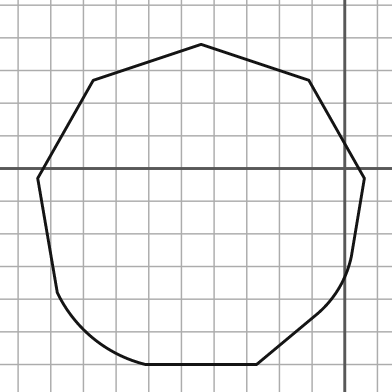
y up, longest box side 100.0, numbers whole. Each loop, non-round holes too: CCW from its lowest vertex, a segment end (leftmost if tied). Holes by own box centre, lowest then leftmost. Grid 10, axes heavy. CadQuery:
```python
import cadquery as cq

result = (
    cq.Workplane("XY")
    .moveTo(-61.0, -60.0)
    .lineTo(-27.0, -60.0)
    .lineTo(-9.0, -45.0)
    .threePointArc((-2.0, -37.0), (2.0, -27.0))
    .lineTo(6.0, -3.0)
    .lineTo(-11.0, 27.0)
    .lineTo(-44.0, 38.0)
    .lineTo(-77.0, 27.0)
    .lineTo(-94.0, -3.0)
    .lineTo(-88.0, -38.0)
    .threePointArc((-77.0, -52.0), (-61.0, -60.0))
    .close()
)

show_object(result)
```